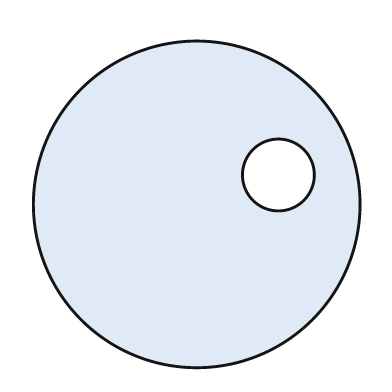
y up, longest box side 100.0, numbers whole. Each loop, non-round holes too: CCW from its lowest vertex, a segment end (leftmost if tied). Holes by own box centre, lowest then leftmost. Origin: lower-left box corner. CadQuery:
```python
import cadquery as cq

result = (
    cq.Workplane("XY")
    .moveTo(50.0, 50.0)
    .circle(50.0)
    .moveTo(75.0, 59.0)
    .circle(11.0)
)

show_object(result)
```